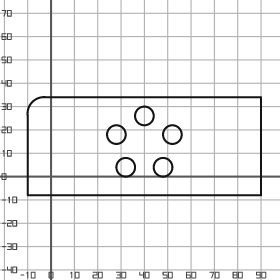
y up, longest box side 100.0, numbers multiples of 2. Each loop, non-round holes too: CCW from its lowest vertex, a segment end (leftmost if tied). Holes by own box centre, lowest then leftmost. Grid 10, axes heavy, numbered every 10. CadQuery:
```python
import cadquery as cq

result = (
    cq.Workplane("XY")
    .moveTo(-10.0, -8.0)
    .lineTo(90.0, -8.0)
    .lineTo(90.0, 34.0)
    .lineTo(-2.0, 34.0)
    .threePointArc((-8.0, 32.0), (-10.0, 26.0))
    .close()
    .moveTo(32.0, 4.0)
    .circle(4.0)
    .moveTo(48.0, 4.0)
    .circle(4.0)
    .moveTo(28.0, 18.0)
    .circle(4.0)
    .moveTo(52.0, 18.0)
    .circle(4.0)
    .moveTo(40.0, 26.0)
    .circle(4.0)
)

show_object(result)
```